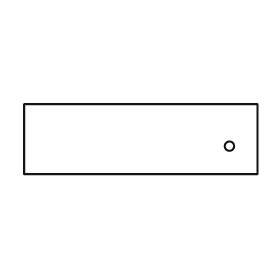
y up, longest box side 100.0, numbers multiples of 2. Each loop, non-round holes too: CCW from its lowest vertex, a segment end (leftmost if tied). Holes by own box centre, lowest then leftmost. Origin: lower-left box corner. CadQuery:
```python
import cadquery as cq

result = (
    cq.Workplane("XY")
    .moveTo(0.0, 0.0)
    .lineTo(100.0, 0.0)
    .lineTo(100.0, 30.0)
    .lineTo(0.0, 30.0)
    .close()
    .moveTo(88.0, 12.0)
    .circle(2.0)
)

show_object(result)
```